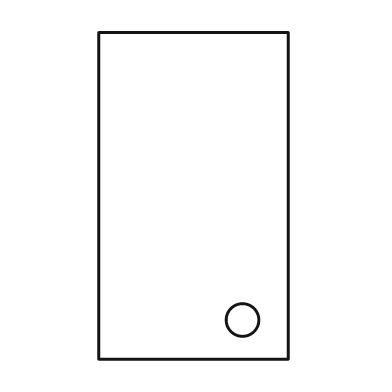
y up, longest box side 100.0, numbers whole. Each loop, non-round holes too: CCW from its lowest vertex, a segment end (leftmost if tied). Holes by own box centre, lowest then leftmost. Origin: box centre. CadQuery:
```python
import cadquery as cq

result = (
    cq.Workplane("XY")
    .moveTo(-29.0, -50.0)
    .lineTo(29.0, -50.0)
    .lineTo(29.0, 50.0)
    .lineTo(-29.0, 50.0)
    .close()
    .moveTo(15.0, -38.0)
    .circle(5.0)
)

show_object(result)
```